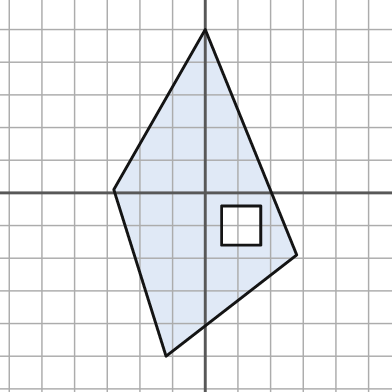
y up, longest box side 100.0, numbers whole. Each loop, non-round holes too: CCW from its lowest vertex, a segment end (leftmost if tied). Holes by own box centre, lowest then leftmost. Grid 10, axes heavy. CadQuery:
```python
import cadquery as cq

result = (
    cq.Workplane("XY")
    .moveTo(-12.0, -50.0)
    .lineTo(28.0, -19.0)
    .lineTo(0.0, 50.0)
    .lineTo(-28.0, 1.0)
    .close()
    .moveTo(5.0, -16.0)
    .lineTo(17.0, -16.0)
    .lineTo(17.0, -4.0)
    .lineTo(5.0, -4.0)
    .close()
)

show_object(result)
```